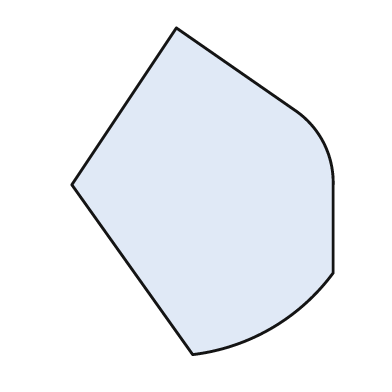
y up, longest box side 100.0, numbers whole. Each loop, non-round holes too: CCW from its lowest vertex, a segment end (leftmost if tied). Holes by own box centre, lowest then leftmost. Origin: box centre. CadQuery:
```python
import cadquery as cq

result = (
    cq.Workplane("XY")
    .moveTo(-3.0, -50.0)
    .threePointArc((21.0, -42.0), (40.0, -25.0))
    .lineTo(40.0, 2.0)
    .threePointArc((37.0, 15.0), (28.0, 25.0))
    .lineTo(-8.0, 50.0)
    .lineTo(-40.0, 2.0)
    .close()
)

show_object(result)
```